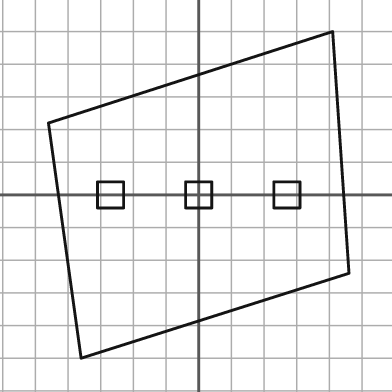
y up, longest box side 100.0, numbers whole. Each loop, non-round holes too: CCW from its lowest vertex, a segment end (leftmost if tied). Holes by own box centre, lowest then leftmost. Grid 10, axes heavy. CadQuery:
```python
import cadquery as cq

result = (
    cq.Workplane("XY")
    .moveTo(-36.0, -50.0)
    .lineTo(46.0, -24.0)
    .lineTo(41.0, 50.0)
    .lineTo(-46.0, 22.0)
    .close()
    .moveTo(-31.0, -4.0)
    .lineTo(-23.0, -4.0)
    .lineTo(-23.0, 4.0)
    .lineTo(-31.0, 4.0)
    .close()
    .moveTo(-4.0, -4.0)
    .lineTo(4.0, -4.0)
    .lineTo(4.0, 4.0)
    .lineTo(-4.0, 4.0)
    .close()
    .moveTo(23.0, -4.0)
    .lineTo(31.0, -4.0)
    .lineTo(31.0, 4.0)
    .lineTo(23.0, 4.0)
    .close()
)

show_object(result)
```